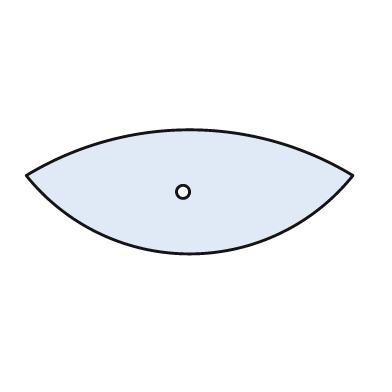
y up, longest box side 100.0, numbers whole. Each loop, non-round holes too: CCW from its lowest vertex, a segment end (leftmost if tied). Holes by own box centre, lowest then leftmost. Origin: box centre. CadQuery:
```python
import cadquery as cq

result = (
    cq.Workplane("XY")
    .moveTo(-50.0, 5.0)
    .threePointArc((0.0, -19.0), (50.0, 5.0))
    .threePointArc((0.0, 19.0), (-50.0, 5.0))
    .close()
    .moveTo(-2.0, 0.0)
    .circle(2.0)
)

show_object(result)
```